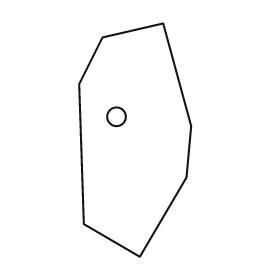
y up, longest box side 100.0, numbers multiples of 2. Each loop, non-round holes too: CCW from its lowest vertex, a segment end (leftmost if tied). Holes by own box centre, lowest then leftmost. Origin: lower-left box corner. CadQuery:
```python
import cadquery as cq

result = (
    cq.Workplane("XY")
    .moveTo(26.0, 0.0)
    .lineTo(46.0, 34.0)
    .lineTo(48.0, 56.0)
    .lineTo(36.0, 100.0)
    .lineTo(10.0, 94.0)
    .lineTo(0.0, 74.0)
    .lineTo(2.0, 14.0)
    .close()
    .moveTo(16.0, 60.0)
    .circle(4.0)
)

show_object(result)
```